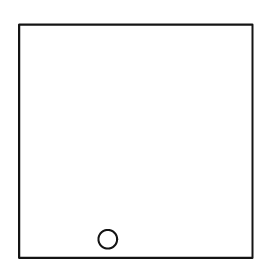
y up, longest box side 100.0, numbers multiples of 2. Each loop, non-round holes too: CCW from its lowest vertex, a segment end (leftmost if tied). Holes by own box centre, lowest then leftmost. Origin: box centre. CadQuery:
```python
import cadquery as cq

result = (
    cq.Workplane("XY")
    .moveTo(-50.0, -50.0)
    .lineTo(50.0, -50.0)
    .lineTo(50.0, 50.0)
    .lineTo(-50.0, 50.0)
    .close()
    .moveTo(-12.0, -42.0)
    .circle(4.0)
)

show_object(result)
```